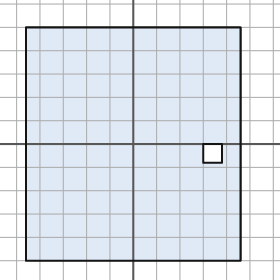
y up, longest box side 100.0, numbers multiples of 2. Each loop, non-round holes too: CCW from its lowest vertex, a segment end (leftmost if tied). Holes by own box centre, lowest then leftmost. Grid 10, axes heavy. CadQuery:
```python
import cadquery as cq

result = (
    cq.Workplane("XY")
    .moveTo(-46.0, -50.0)
    .lineTo(46.0, -50.0)
    .lineTo(46.0, 50.0)
    .lineTo(-46.0, 50.0)
    .close()
    .moveTo(30.0, -8.0)
    .lineTo(38.0, -8.0)
    .lineTo(38.0, 0.0)
    .lineTo(30.0, 0.0)
    .close()
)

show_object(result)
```